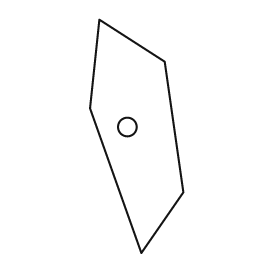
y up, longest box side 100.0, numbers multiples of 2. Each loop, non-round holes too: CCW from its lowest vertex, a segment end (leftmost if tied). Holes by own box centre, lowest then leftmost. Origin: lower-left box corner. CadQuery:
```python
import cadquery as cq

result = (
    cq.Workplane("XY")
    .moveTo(22.0, 0.0)
    .lineTo(40.0, 26.0)
    .lineTo(32.0, 82.0)
    .lineTo(4.0, 100.0)
    .lineTo(0.0, 62.0)
    .close()
    .moveTo(16.0, 54.0)
    .circle(4.0)
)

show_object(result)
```